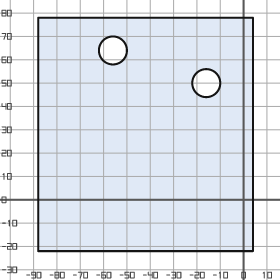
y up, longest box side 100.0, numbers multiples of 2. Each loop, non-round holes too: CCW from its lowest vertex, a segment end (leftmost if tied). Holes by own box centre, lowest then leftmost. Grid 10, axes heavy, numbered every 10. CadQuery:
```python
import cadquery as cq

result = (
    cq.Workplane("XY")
    .moveTo(-88.0, -22.0)
    .lineTo(4.0, -22.0)
    .lineTo(4.0, 78.0)
    .lineTo(-88.0, 78.0)
    .close()
    .moveTo(-16.0, 50.0)
    .circle(6.0)
    .moveTo(-56.0, 64.0)
    .circle(6.0)
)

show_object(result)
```